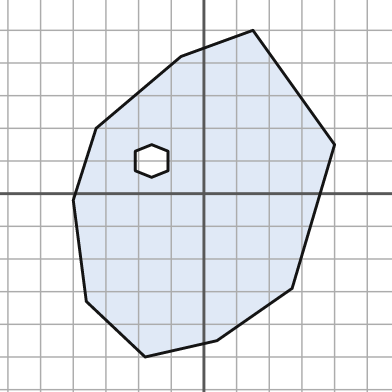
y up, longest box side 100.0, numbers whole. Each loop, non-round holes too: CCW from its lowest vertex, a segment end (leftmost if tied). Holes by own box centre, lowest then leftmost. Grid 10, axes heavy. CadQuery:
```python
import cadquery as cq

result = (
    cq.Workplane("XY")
    .moveTo(-18.0, -50.0)
    .lineTo(4.0, -45.0)
    .lineTo(27.0, -29.0)
    .lineTo(40.0, 15.0)
    .lineTo(15.0, 50.0)
    .lineTo(-7.0, 42.0)
    .lineTo(-33.0, 20.0)
    .lineTo(-40.0, -2.0)
    .lineTo(-36.0, -33.0)
    .close()
    .moveTo(-16.0, 5.0)
    .lineTo(-11.0, 7.0)
    .lineTo(-11.0, 13.0)
    .lineTo(-16.0, 15.0)
    .lineTo(-21.0, 13.0)
    .lineTo(-21.0, 7.0)
    .close()
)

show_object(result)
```